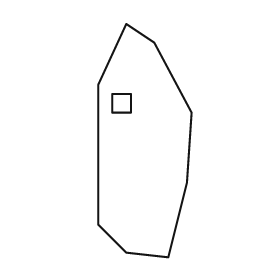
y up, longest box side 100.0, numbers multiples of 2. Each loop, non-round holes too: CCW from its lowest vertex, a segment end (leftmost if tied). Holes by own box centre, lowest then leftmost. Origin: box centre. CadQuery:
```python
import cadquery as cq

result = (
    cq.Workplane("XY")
    .moveTo(10.0, -50.0)
    .lineTo(18.0, -18.0)
    .lineTo(20.0, 12.0)
    .lineTo(4.0, 42.0)
    .lineTo(-8.0, 50.0)
    .lineTo(-20.0, 24.0)
    .lineTo(-20.0, -36.0)
    .lineTo(-8.0, -48.0)
    .close()
    .moveTo(-14.0, 12.0)
    .lineTo(-6.0, 12.0)
    .lineTo(-6.0, 20.0)
    .lineTo(-14.0, 20.0)
    .close()
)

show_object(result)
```